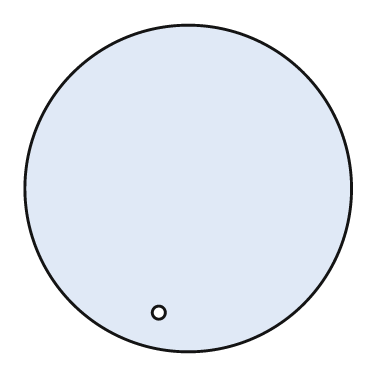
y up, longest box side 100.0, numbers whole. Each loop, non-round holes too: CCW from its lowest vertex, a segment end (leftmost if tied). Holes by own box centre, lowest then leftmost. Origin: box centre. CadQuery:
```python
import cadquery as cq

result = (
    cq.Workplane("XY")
    .moveTo(0.0, 0.0)
    .circle(50.0)
    .moveTo(-9.0, -38.0)
    .circle(2.0)
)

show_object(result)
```